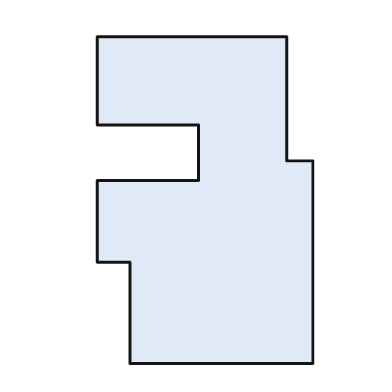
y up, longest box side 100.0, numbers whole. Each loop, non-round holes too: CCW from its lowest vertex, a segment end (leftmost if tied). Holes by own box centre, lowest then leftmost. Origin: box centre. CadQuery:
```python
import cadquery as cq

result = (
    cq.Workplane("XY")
    .moveTo(-23.0, -50.0)
    .lineTo(33.0, -50.0)
    .lineTo(33.0, 12.0)
    .lineTo(25.0, 12.0)
    .lineTo(25.0, 50.0)
    .lineTo(-33.0, 50.0)
    .lineTo(-33.0, 23.0)
    .lineTo(-2.0, 23.0)
    .lineTo(-2.0, 6.0)
    .lineTo(-33.0, 6.0)
    .lineTo(-33.0, -19.0)
    .lineTo(-23.0, -19.0)
    .close()
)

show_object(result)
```